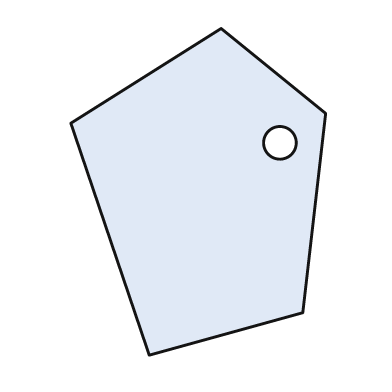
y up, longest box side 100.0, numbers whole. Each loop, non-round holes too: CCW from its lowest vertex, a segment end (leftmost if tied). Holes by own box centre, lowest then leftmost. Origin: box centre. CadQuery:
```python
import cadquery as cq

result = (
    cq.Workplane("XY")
    .moveTo(-15.0, -50.0)
    .lineTo(32.0, -37.0)
    .lineTo(39.0, 24.0)
    .lineTo(7.0, 50.0)
    .lineTo(-39.0, 21.0)
    .close()
    .moveTo(25.0, 15.0)
    .circle(5.0)
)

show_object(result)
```